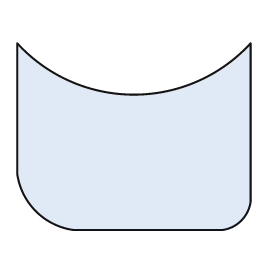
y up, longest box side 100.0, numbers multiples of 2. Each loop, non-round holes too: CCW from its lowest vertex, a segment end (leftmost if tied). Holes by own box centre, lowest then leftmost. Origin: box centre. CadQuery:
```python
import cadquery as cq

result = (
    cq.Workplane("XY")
    .moveTo(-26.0, -40.0)
    .lineTo(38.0, -40.0)
    .threePointArc((46.0, -36.0), (50.0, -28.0))
    .lineTo(50.0, 40.0)
    .threePointArc((0.0, 18.0), (-50.0, 40.0))
    .lineTo(-50.0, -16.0)
    .threePointArc((-42.0, -32.0), (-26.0, -40.0))
    .close()
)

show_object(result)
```